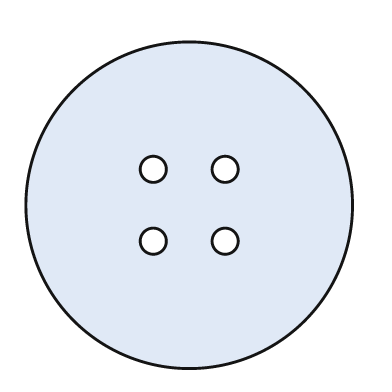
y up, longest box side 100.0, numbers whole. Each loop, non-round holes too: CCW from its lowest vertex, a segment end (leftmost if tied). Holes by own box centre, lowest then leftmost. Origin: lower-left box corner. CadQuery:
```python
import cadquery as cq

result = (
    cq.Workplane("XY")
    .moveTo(50.0, 50.0)
    .circle(50.0)
    .moveTo(39.0, 39.0)
    .circle(4.0)
    .moveTo(61.0, 39.0)
    .circle(4.0)
    .moveTo(39.0, 61.0)
    .circle(4.0)
    .moveTo(61.0, 61.0)
    .circle(4.0)
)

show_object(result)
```